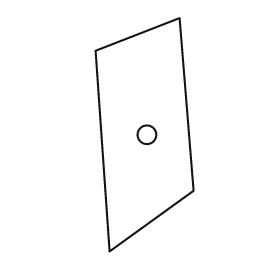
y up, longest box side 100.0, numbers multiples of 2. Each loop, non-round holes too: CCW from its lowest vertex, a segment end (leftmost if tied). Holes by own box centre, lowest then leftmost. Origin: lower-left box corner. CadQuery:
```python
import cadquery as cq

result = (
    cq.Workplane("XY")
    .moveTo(6.0, 0.0)
    .lineTo(42.0, 26.0)
    .lineTo(36.0, 100.0)
    .lineTo(0.0, 86.0)
    .close()
    .moveTo(22.0, 50.0)
    .circle(4.0)
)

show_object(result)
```